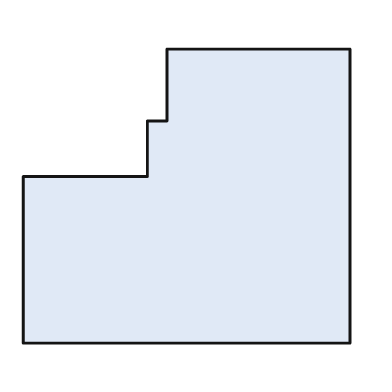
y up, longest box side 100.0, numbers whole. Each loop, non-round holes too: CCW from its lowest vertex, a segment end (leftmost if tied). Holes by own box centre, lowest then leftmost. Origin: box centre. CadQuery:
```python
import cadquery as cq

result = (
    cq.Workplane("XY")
    .moveTo(-50.0, -45.0)
    .lineTo(50.0, -45.0)
    .lineTo(50.0, 45.0)
    .lineTo(-6.0, 45.0)
    .lineTo(-6.0, 23.0)
    .lineTo(-12.0, 23.0)
    .lineTo(-12.0, 6.0)
    .lineTo(-50.0, 6.0)
    .close()
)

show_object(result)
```